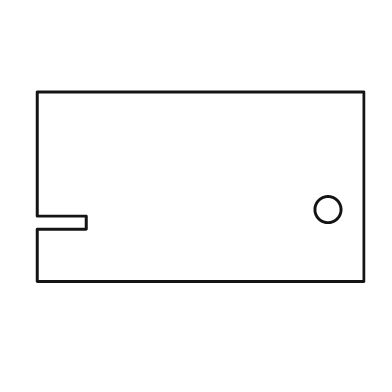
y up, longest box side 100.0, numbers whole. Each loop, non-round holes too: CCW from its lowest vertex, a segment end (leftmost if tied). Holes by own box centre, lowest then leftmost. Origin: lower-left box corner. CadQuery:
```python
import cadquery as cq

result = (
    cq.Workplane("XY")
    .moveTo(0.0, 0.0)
    .lineTo(100.0, 0.0)
    .lineTo(100.0, 58.0)
    .lineTo(0.0, 58.0)
    .lineTo(0.0, 20.0)
    .lineTo(15.0, 20.0)
    .lineTo(15.0, 16.0)
    .lineTo(0.0, 16.0)
    .close()
    .moveTo(89.0, 22.0)
    .circle(4.0)
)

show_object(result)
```